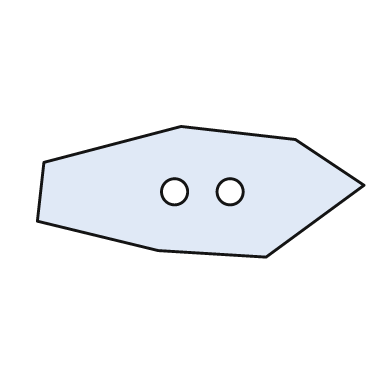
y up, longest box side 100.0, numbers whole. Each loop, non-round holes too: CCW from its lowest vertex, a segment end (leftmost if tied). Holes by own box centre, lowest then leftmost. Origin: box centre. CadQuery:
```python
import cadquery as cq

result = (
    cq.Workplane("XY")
    .moveTo(20.0, -20.0)
    .lineTo(50.0, 2.0)
    .lineTo(29.0, 16.0)
    .lineTo(-6.0, 20.0)
    .lineTo(-48.0, 9.0)
    .lineTo(-50.0, -9.0)
    .lineTo(-13.0, -18.0)
    .close()
    .moveTo(-8.0, 0.0)
    .circle(4.0)
    .moveTo(9.0, 0.0)
    .circle(4.0)
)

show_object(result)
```